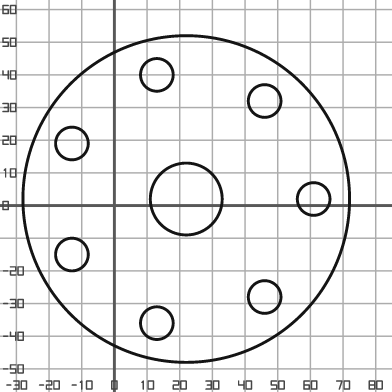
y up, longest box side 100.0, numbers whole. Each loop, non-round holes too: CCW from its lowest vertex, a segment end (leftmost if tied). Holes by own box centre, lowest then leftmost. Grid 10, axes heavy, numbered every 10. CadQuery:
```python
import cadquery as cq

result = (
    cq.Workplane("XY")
    .moveTo(22.0, 2.0)
    .circle(50.0)
    .moveTo(13.0, -36.0)
    .circle(5.0)
    .moveTo(46.0, -28.0)
    .circle(5.0)
    .moveTo(-13.0, -15.0)
    .circle(5.0)
    .moveTo(22.0, 2.0)
    .circle(11.0)
    .moveTo(61.0, 2.0)
    .circle(5.0)
    .moveTo(-13.0, 19.0)
    .circle(5.0)
    .moveTo(46.0, 32.0)
    .circle(5.0)
    .moveTo(13.0, 40.0)
    .circle(5.0)
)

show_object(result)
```